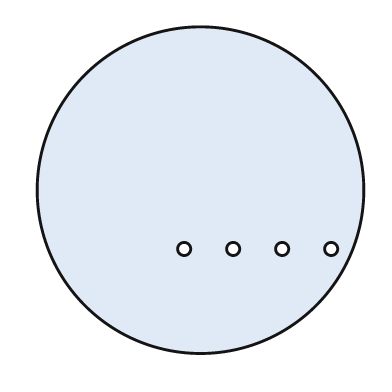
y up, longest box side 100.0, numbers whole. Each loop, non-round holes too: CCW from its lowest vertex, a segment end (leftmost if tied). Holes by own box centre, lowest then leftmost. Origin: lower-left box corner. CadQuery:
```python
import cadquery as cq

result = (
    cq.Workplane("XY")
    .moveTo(50.0, 50.0)
    .circle(50.0)
    .moveTo(45.0, 32.0)
    .circle(2.0)
    .moveTo(60.0, 32.0)
    .circle(2.0)
    .moveTo(75.0, 32.0)
    .circle(2.0)
    .moveTo(90.0, 32.0)
    .circle(2.0)
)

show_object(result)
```